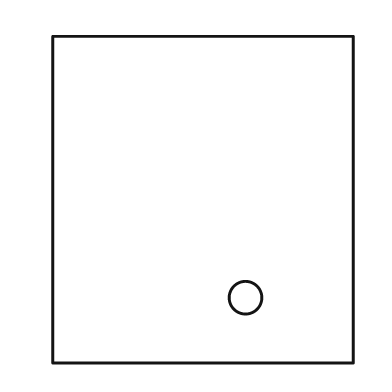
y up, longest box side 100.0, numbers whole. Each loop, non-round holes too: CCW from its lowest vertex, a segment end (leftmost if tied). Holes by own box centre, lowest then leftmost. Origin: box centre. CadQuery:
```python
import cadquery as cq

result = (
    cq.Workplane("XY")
    .moveTo(-46.0, -50.0)
    .lineTo(46.0, -50.0)
    .lineTo(46.0, 50.0)
    .lineTo(-46.0, 50.0)
    .close()
    .moveTo(13.0, -30.0)
    .circle(5.0)
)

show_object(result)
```